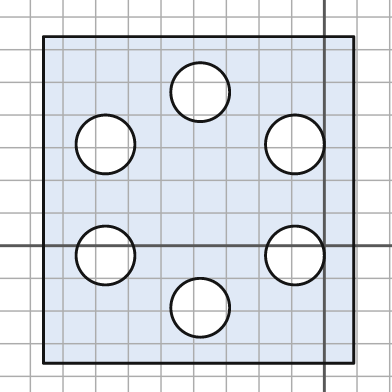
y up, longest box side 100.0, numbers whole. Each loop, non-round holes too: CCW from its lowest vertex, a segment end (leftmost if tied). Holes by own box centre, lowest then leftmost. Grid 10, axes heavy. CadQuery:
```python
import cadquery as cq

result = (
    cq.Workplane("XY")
    .moveTo(-86.0, -36.0)
    .lineTo(9.0, -36.0)
    .lineTo(9.0, 64.0)
    .lineTo(-86.0, 64.0)
    .close()
    .moveTo(-38.0, -19.0)
    .circle(9.0)
    .moveTo(-67.0, -3.0)
    .circle(9.0)
    .moveTo(-9.0, -3.0)
    .circle(9.0)
    .moveTo(-67.0, 31.0)
    .circle(9.0)
    .moveTo(-9.0, 31.0)
    .circle(9.0)
    .moveTo(-38.0, 47.0)
    .circle(9.0)
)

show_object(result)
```